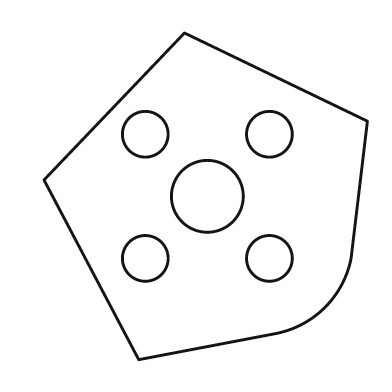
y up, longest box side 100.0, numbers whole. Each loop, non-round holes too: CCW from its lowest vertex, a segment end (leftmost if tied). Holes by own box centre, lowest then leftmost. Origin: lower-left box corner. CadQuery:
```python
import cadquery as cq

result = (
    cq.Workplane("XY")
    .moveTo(29.0, 0.0)
    .lineTo(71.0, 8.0)
    .threePointArc((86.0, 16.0), (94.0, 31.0))
    .lineTo(99.0, 73.0)
    .lineTo(43.0, 100.0)
    .lineTo(0.0, 55.0)
    .close()
    .moveTo(31.0, 31.0)
    .circle(7.0)
    .moveTo(69.0, 31.0)
    .circle(7.0)
    .moveTo(50.0, 50.0)
    .circle(11.0)
    .moveTo(31.0, 69.0)
    .circle(7.0)
    .moveTo(69.0, 69.0)
    .circle(7.0)
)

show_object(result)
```